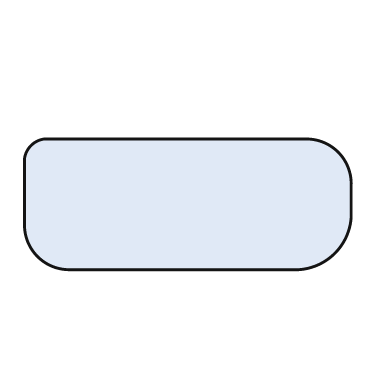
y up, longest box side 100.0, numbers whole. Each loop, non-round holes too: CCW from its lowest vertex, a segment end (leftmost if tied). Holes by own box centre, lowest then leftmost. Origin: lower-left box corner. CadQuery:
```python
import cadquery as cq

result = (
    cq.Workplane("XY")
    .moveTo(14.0, 0.0)
    .lineTo(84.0, 0.0)
    .threePointArc((95.0, 5.0), (100.0, 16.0))
    .lineTo(100.0, 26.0)
    .threePointArc((96.0, 36.0), (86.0, 40.0))
    .lineTo(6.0, 40.0)
    .threePointArc((2.0, 38.0), (0.0, 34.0))
    .lineTo(0.0, 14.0)
    .threePointArc((4.0, 4.0), (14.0, 0.0))
    .close()
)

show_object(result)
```